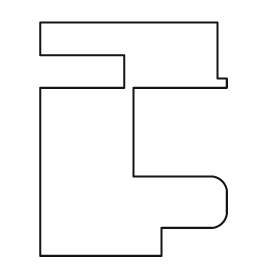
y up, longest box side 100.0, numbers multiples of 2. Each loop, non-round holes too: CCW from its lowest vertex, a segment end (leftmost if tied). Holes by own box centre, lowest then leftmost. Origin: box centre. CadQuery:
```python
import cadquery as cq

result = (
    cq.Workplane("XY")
    .moveTo(-40.0, -50.0)
    .lineTo(12.0, -50.0)
    .lineTo(12.0, -38.0)
    .lineTo(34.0, -38.0)
    .threePointArc((38.0, -36.0), (40.0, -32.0))
    .lineTo(40.0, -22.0)
    .threePointArc((38.0, -18.0), (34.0, -16.0))
    .lineTo(0.0, -16.0)
    .lineTo(0.0, 22.0)
    .lineTo(40.0, 22.0)
    .lineTo(40.0, 26.0)
    .lineTo(36.0, 26.0)
    .lineTo(36.0, 50.0)
    .lineTo(-40.0, 50.0)
    .lineTo(-40.0, 36.0)
    .lineTo(-4.0, 36.0)
    .lineTo(-4.0, 22.0)
    .lineTo(-40.0, 22.0)
    .close()
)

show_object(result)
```